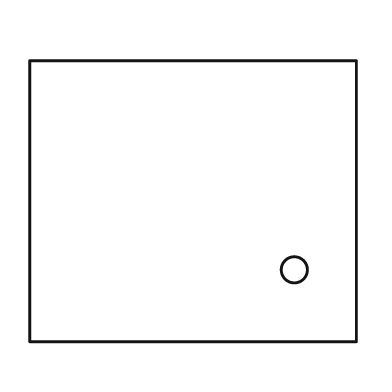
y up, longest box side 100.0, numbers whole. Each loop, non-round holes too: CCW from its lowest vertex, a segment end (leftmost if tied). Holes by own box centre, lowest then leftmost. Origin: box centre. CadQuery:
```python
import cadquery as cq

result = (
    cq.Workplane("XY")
    .moveTo(-50.0, -43.0)
    .lineTo(50.0, -43.0)
    .lineTo(50.0, 43.0)
    .lineTo(-50.0, 43.0)
    .close()
    .moveTo(31.0, -21.0)
    .circle(4.0)
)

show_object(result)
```